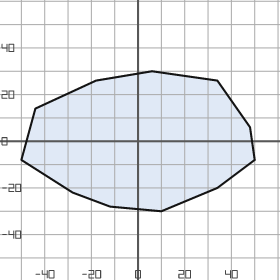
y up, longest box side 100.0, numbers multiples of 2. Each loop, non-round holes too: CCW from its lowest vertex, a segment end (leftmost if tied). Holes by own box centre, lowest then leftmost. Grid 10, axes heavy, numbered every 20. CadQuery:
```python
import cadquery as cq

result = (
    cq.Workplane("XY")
    .moveTo(10.0, -30.0)
    .lineTo(34.0, -20.0)
    .lineTo(50.0, -8.0)
    .lineTo(48.0, 6.0)
    .lineTo(34.0, 26.0)
    .lineTo(6.0, 30.0)
    .lineTo(-18.0, 26.0)
    .lineTo(-44.0, 14.0)
    .lineTo(-50.0, -8.0)
    .lineTo(-28.0, -22.0)
    .lineTo(-12.0, -28.0)
    .close()
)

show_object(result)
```